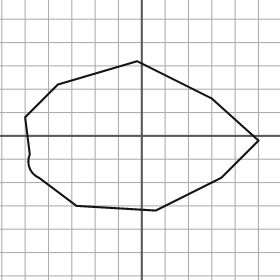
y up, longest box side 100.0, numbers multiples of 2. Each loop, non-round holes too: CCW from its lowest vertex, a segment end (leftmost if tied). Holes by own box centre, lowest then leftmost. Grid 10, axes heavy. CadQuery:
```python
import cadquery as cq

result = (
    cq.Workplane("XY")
    .moveTo(6.0, -32.0)
    .lineTo(34.0, -18.0)
    .lineTo(50.0, -2.0)
    .lineTo(30.0, 16.0)
    .lineTo(-2.0, 32.0)
    .lineTo(-36.0, 22.0)
    .lineTo(-50.0, 8.0)
    .lineTo(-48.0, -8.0)
    .threePointArc((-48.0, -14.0), (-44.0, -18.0))
    .lineTo(-28.0, -30.0)
    .close()
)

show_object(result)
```